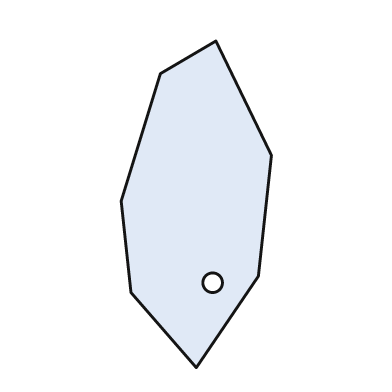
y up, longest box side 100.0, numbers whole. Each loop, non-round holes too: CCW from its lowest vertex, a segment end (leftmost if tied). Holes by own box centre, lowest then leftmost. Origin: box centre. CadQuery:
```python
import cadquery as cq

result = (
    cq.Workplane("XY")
    .moveTo(0.0, -50.0)
    .lineTo(19.0, -22.0)
    .lineTo(23.0, 15.0)
    .lineTo(6.0, 50.0)
    .lineTo(-11.0, 40.0)
    .lineTo(-23.0, 1.0)
    .lineTo(-20.0, -27.0)
    .close()
    .moveTo(5.0, -24.0)
    .circle(3.0)
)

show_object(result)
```